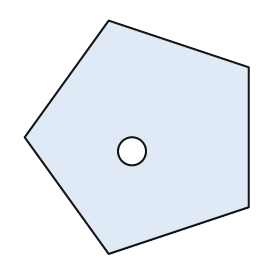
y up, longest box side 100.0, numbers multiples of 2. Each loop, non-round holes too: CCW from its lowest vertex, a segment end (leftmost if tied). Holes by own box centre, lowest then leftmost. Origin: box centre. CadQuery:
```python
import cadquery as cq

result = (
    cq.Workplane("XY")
    .moveTo(-12.0, -50.0)
    .lineTo(48.0, -30.0)
    .lineTo(48.0, 30.0)
    .lineTo(-12.0, 50.0)
    .lineTo(-48.0, 0.0)
    .close()
    .moveTo(-2.0, -6.0)
    .circle(6.0)
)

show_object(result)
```